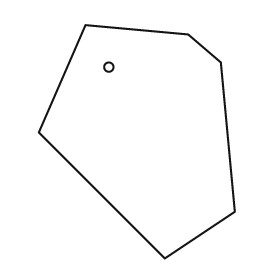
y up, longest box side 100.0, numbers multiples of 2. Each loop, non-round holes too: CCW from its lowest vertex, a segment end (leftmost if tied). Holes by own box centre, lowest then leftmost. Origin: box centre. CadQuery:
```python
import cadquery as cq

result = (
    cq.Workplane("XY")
    .moveTo(12.0, -50.0)
    .lineTo(42.0, -30.0)
    .lineTo(36.0, 34.0)
    .lineTo(22.0, 46.0)
    .lineTo(-22.0, 50.0)
    .lineTo(-42.0, 4.0)
    .close()
    .moveTo(-12.0, 32.0)
    .circle(2.0)
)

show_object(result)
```